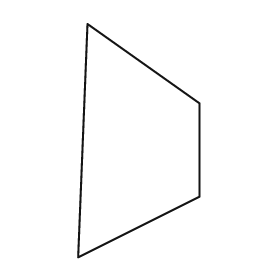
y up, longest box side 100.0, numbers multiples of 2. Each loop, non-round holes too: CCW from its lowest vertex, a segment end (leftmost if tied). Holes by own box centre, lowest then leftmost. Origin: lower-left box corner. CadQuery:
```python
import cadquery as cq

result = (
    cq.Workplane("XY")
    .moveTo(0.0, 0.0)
    .lineTo(52.0, 26.0)
    .lineTo(52.0, 66.0)
    .lineTo(4.0, 100.0)
    .close()
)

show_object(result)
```